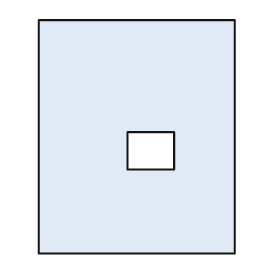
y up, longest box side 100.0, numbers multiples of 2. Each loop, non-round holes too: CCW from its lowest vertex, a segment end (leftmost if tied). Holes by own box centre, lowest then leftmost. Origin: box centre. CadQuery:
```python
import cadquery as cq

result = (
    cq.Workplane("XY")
    .moveTo(-42.0, -50.0)
    .lineTo(42.0, -50.0)
    .lineTo(42.0, 50.0)
    .lineTo(-42.0, 50.0)
    .close()
    .moveTo(-4.0, -14.0)
    .lineTo(16.0, -14.0)
    .lineTo(16.0, 2.0)
    .lineTo(-4.0, 2.0)
    .close()
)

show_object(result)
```